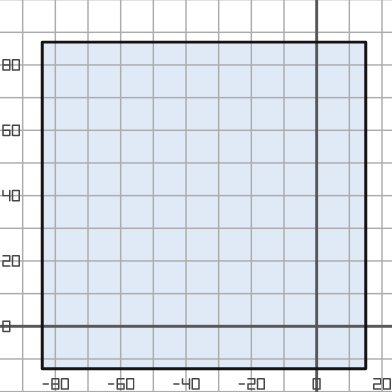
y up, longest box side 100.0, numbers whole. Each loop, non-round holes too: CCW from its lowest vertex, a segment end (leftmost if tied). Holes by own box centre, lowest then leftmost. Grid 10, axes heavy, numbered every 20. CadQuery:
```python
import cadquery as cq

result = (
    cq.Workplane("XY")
    .moveTo(-84.0, -13.0)
    .lineTo(15.0, -13.0)
    .lineTo(15.0, 87.0)
    .lineTo(-84.0, 87.0)
    .close()
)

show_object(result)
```